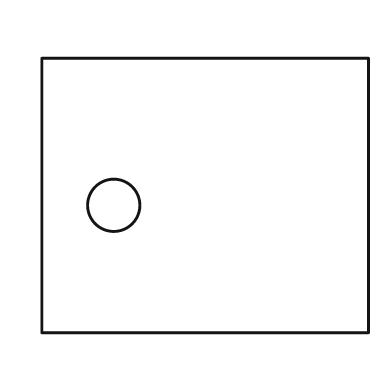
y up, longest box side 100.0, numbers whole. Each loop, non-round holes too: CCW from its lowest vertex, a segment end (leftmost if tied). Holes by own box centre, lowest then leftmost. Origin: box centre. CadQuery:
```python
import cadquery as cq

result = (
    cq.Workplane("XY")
    .moveTo(-50.0, -42.0)
    .lineTo(50.0, -42.0)
    .lineTo(50.0, 42.0)
    .lineTo(-50.0, 42.0)
    .close()
    .moveTo(-28.0, -3.0)
    .circle(8.0)
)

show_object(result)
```